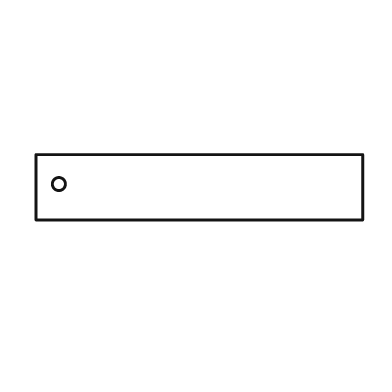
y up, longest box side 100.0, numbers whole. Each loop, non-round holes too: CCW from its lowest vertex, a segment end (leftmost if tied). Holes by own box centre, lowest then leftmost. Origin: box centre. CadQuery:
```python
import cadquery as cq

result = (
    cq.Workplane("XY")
    .moveTo(-50.0, -10.0)
    .lineTo(50.0, -10.0)
    .lineTo(50.0, 10.0)
    .lineTo(-50.0, 10.0)
    .close()
    .moveTo(-43.0, 1.0)
    .circle(2.0)
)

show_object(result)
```